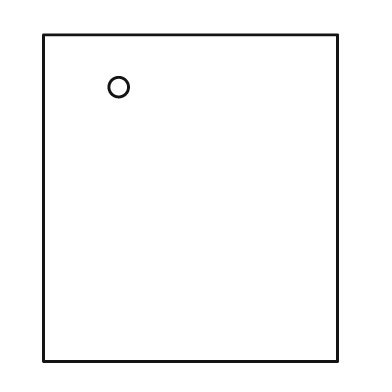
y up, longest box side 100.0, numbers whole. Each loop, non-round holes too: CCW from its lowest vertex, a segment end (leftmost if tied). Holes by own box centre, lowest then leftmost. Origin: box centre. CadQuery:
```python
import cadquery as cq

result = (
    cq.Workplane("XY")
    .moveTo(-45.0, -50.0)
    .lineTo(45.0, -50.0)
    .lineTo(45.0, 50.0)
    .lineTo(-45.0, 50.0)
    .close()
    .moveTo(-22.0, 34.0)
    .circle(3.0)
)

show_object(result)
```